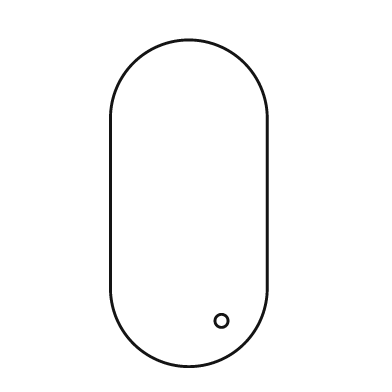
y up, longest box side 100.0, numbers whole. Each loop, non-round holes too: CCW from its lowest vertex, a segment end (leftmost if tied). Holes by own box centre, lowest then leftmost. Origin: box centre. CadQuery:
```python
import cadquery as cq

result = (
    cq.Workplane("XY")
    .moveTo(-24.0, -26.0)
    .threePointArc((0.0, -50.0), (24.0, -26.0))
    .lineTo(24.0, 26.0)
    .threePointArc((0.0, 50.0), (-24.0, 26.0))
    .close()
    .moveTo(10.0, -36.0)
    .circle(2.0)
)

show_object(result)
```